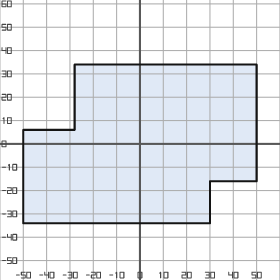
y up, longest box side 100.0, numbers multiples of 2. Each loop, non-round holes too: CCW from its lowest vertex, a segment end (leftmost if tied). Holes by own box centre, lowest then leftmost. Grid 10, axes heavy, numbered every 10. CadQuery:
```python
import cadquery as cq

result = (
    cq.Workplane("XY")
    .moveTo(-50.0, -34.0)
    .lineTo(30.0, -34.0)
    .lineTo(30.0, -16.0)
    .lineTo(50.0, -16.0)
    .lineTo(50.0, 34.0)
    .lineTo(-28.0, 34.0)
    .lineTo(-28.0, 6.0)
    .lineTo(-50.0, 6.0)
    .close()
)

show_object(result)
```